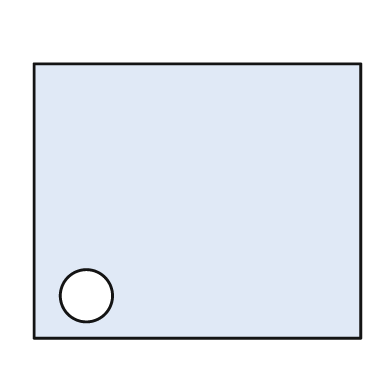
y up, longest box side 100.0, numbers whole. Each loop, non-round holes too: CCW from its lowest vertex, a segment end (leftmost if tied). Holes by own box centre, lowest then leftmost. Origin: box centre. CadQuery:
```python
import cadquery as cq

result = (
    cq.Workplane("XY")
    .moveTo(-50.0, -42.0)
    .lineTo(50.0, -42.0)
    .lineTo(50.0, 42.0)
    .lineTo(-50.0, 42.0)
    .close()
    .moveTo(-34.0, -29.0)
    .circle(8.0)
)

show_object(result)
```